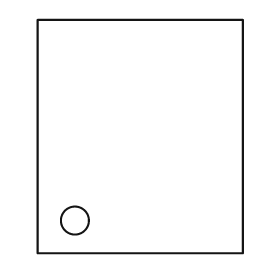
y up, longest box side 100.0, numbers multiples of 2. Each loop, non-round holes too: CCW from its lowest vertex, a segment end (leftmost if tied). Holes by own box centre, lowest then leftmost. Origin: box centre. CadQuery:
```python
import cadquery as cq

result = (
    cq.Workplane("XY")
    .moveTo(-44.0, -50.0)
    .lineTo(44.0, -50.0)
    .lineTo(44.0, 50.0)
    .lineTo(-44.0, 50.0)
    .close()
    .moveTo(-28.0, -36.0)
    .circle(6.0)
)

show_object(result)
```